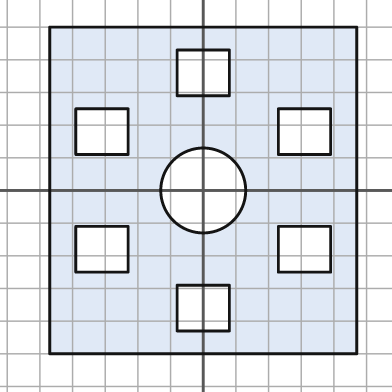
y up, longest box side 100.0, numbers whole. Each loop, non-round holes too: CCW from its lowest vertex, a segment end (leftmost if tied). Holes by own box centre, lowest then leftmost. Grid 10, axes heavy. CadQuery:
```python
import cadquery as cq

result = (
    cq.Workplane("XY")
    .moveTo(-47.0, -50.0)
    .lineTo(47.0, -50.0)
    .lineTo(47.0, 50.0)
    .lineTo(-47.0, 50.0)
    .close()
    .moveTo(-8.0, -43.0)
    .lineTo(8.0, -43.0)
    .lineTo(8.0, -29.0)
    .lineTo(-8.0, -29.0)
    .close()
    .moveTo(-39.0, -25.0)
    .lineTo(-23.0, -25.0)
    .lineTo(-23.0, -11.0)
    .lineTo(-39.0, -11.0)
    .close()
    .moveTo(23.0, -25.0)
    .lineTo(39.0, -25.0)
    .lineTo(39.0, -11.0)
    .lineTo(23.0, -11.0)
    .close()
    .moveTo(0.0, 0.0)
    .circle(13.0)
    .moveTo(-39.0, 11.0)
    .lineTo(-23.0, 11.0)
    .lineTo(-23.0, 25.0)
    .lineTo(-39.0, 25.0)
    .close()
    .moveTo(23.0, 11.0)
    .lineTo(39.0, 11.0)
    .lineTo(39.0, 25.0)
    .lineTo(23.0, 25.0)
    .close()
    .moveTo(-8.0, 29.0)
    .lineTo(8.0, 29.0)
    .lineTo(8.0, 43.0)
    .lineTo(-8.0, 43.0)
    .close()
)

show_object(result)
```